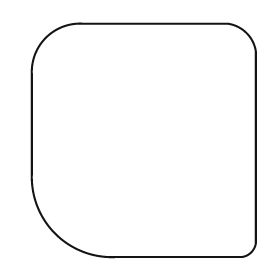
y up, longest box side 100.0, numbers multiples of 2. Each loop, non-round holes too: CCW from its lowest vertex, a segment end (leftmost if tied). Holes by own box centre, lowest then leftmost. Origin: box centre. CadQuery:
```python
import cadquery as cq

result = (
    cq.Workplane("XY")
    .moveTo(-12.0, -50.0)
    .lineTo(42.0, -50.0)
    .threePointArc((46.0, -48.0), (48.0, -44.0))
    .lineTo(48.0, 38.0)
    .threePointArc((44.0, 46.0), (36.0, 50.0))
    .lineTo(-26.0, 50.0)
    .threePointArc((-42.0, 44.0), (-48.0, 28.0))
    .lineTo(-48.0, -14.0)
    .threePointArc((-38.0, -40.0), (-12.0, -50.0))
    .close()
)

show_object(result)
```